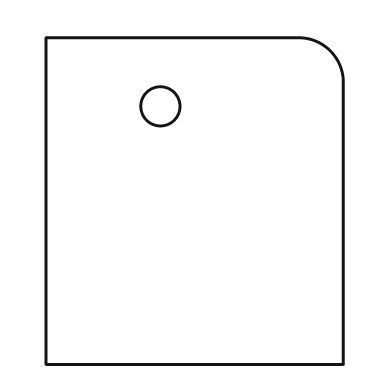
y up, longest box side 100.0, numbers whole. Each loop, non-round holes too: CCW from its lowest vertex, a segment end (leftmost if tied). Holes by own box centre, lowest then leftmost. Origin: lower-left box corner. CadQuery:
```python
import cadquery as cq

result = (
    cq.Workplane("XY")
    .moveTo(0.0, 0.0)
    .lineTo(91.0, 0.0)
    .lineTo(91.0, 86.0)
    .threePointArc((87.0, 96.0), (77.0, 100.0))
    .lineTo(0.0, 100.0)
    .close()
    .moveTo(35.0, 79.0)
    .circle(6.0)
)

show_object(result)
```